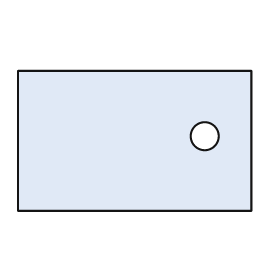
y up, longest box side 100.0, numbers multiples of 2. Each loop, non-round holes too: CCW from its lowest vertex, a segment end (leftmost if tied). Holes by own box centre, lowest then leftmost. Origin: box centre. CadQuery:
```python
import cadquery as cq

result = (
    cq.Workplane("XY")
    .moveTo(-50.0, -30.0)
    .lineTo(50.0, -30.0)
    .lineTo(50.0, 30.0)
    .lineTo(-50.0, 30.0)
    .close()
    .moveTo(30.0, 2.0)
    .circle(6.0)
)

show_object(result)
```